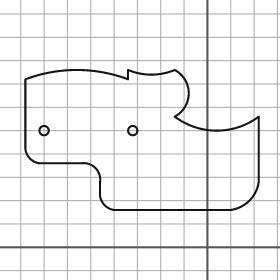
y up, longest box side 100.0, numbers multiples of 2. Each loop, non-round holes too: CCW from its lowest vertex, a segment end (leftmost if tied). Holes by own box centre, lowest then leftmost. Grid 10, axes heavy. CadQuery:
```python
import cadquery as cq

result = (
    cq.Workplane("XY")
    .moveTo(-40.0, 16.0)
    .lineTo(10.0, 16.0)
    .threePointArc((18.0, 20.0), (22.0, 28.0))
    .lineTo(22.0, 56.0)
    .threePointArc((4.0, 50.0), (-14.0, 56.0))
    .threePointArc((-8.0, 66.0), (-14.0, 76.0))
    .threePointArc((-24.0, 74.0), (-34.0, 76.0))
    .lineTo(-34.0, 72.0)
    .threePointArc((-56.0, 76.0), (-78.0, 72.0))
    .lineTo(-78.0, 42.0)
    .threePointArc((-76.0, 38.0), (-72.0, 36.0))
    .lineTo(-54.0, 36.0)
    .threePointArc((-48.0, 34.0), (-46.0, 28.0))
    .lineTo(-46.0, 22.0)
    .threePointArc((-44.0, 18.0), (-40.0, 16.0))
    .close()
    .moveTo(-70.0, 50.0)
    .circle(2.0)
    .moveTo(-32.0, 50.0)
    .circle(2.0)
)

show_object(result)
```